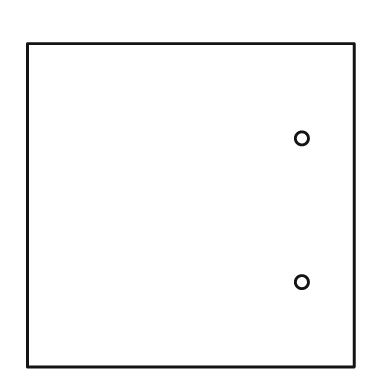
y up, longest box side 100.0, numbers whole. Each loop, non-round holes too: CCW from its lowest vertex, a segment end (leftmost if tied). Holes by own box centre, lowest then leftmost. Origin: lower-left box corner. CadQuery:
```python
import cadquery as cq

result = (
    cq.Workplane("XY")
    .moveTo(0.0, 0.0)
    .lineTo(100.0, 0.0)
    .lineTo(100.0, 99.0)
    .lineTo(0.0, 99.0)
    .close()
    .moveTo(84.0, 26.0)
    .circle(2.0)
    .moveTo(84.0, 70.0)
    .circle(2.0)
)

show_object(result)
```